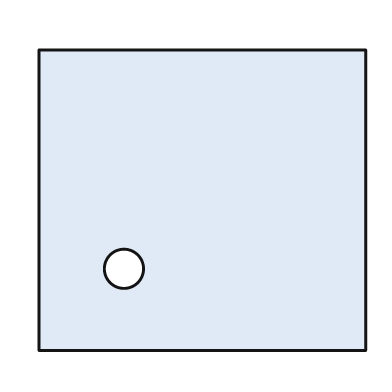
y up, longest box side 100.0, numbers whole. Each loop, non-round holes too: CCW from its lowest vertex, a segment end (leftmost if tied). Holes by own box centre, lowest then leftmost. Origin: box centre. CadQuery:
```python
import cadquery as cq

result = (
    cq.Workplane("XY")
    .moveTo(-50.0, -46.0)
    .lineTo(50.0, -46.0)
    .lineTo(50.0, 46.0)
    .lineTo(-50.0, 46.0)
    .close()
    .moveTo(-24.0, -21.0)
    .circle(6.0)
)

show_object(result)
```